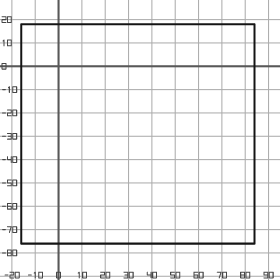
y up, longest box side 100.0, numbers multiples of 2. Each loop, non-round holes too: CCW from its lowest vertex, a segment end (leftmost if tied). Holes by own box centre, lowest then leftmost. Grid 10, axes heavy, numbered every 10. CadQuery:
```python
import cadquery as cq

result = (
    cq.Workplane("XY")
    .moveTo(-16.0, -76.0)
    .lineTo(84.0, -76.0)
    .lineTo(84.0, 18.0)
    .lineTo(-16.0, 18.0)
    .close()
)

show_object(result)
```